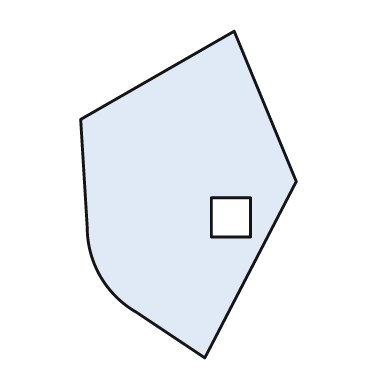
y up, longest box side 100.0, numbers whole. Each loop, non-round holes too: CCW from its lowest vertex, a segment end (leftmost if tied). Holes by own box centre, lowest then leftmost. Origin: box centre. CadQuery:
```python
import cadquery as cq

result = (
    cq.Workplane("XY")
    .moveTo(5.0, -50.0)
    .lineTo(33.0, 4.0)
    .lineTo(14.0, 50.0)
    .lineTo(-33.0, 23.0)
    .lineTo(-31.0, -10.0)
    .threePointArc((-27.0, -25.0), (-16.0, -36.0))
    .close()
    .moveTo(7.0, -13.0)
    .lineTo(19.0, -13.0)
    .lineTo(19.0, -1.0)
    .lineTo(7.0, -1.0)
    .close()
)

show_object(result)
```